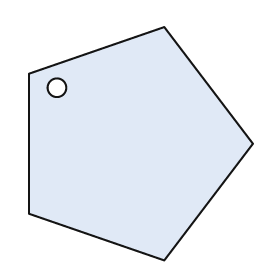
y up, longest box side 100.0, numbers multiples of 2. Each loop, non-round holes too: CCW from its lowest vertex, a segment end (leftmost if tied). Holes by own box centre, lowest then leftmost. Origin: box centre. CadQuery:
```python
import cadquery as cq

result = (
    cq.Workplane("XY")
    .moveTo(10.0, -50.0)
    .lineTo(48.0, 0.0)
    .lineTo(10.0, 50.0)
    .lineTo(-48.0, 30.0)
    .lineTo(-48.0, -30.0)
    .close()
    .moveTo(-36.0, 24.0)
    .circle(4.0)
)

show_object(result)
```